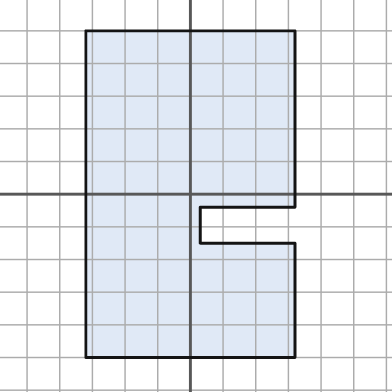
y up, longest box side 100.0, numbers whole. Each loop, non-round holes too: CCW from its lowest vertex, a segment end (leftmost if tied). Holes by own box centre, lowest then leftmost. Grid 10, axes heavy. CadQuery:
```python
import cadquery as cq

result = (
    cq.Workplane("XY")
    .moveTo(-32.0, -50.0)
    .lineTo(32.0, -50.0)
    .lineTo(32.0, -15.0)
    .lineTo(3.0, -15.0)
    .lineTo(3.0, -4.0)
    .lineTo(32.0, -4.0)
    .lineTo(32.0, 50.0)
    .lineTo(-32.0, 50.0)
    .close()
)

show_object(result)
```